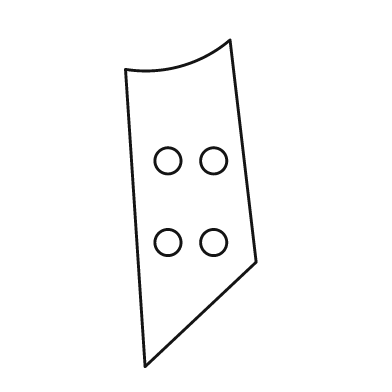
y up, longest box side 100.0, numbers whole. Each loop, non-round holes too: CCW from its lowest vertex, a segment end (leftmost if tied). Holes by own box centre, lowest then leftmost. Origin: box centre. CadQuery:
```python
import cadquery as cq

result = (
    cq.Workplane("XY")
    .moveTo(-14.0, -50.0)
    .lineTo(20.0, -18.0)
    .lineTo(12.0, 50.0)
    .threePointArc((-3.0, 42.0), (-20.0, 41.0))
    .close()
    .moveTo(-7.0, -12.0)
    .circle(4.0)
    .moveTo(7.0, -12.0)
    .circle(4.0)
    .moveTo(-7.0, 13.0)
    .circle(4.0)
    .moveTo(7.0, 13.0)
    .circle(4.0)
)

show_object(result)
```